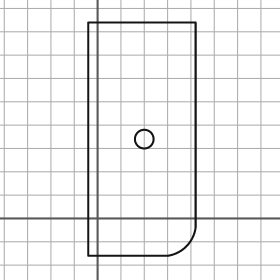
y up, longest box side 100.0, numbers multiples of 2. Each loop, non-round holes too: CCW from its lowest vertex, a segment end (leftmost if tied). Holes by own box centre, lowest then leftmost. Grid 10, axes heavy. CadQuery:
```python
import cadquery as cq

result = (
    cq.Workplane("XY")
    .moveTo(-4.0, -16.0)
    .lineTo(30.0, -16.0)
    .threePointArc((38.0, -12.0), (42.0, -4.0))
    .lineTo(42.0, 84.0)
    .lineTo(-4.0, 84.0)
    .close()
    .moveTo(20.0, 34.0)
    .circle(4.0)
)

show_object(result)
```